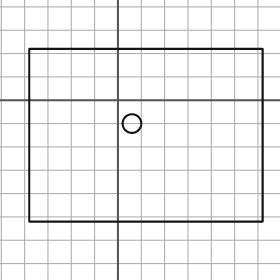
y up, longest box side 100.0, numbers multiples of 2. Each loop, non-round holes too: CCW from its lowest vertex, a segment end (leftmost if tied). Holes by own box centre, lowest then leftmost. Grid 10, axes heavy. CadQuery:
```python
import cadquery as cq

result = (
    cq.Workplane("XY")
    .moveTo(-38.0, -52.0)
    .lineTo(62.0, -52.0)
    .lineTo(62.0, 22.0)
    .lineTo(-38.0, 22.0)
    .close()
    .moveTo(6.0, -10.0)
    .circle(4.0)
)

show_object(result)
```